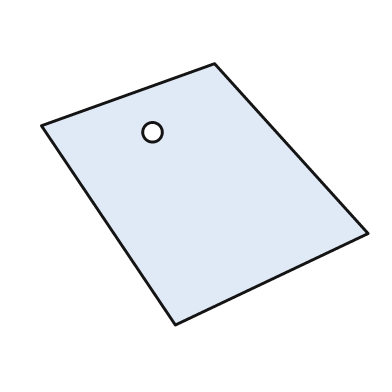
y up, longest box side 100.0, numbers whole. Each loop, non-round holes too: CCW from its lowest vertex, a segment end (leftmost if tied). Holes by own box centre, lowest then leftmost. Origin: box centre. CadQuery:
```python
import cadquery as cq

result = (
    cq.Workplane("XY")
    .moveTo(-9.0, -40.0)
    .lineTo(50.0, -12.0)
    .lineTo(3.0, 40.0)
    .lineTo(-50.0, 21.0)
    .close()
    .moveTo(-16.0, 19.0)
    .circle(3.0)
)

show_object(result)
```